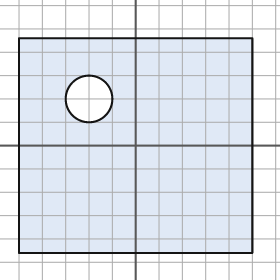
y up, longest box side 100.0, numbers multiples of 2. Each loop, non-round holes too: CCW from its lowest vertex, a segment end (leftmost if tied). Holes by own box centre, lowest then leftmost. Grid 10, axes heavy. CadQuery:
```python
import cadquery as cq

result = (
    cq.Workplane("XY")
    .moveTo(-50.0, -46.0)
    .lineTo(50.0, -46.0)
    .lineTo(50.0, 46.0)
    .lineTo(-50.0, 46.0)
    .close()
    .moveTo(-20.0, 20.0)
    .circle(10.0)
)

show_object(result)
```